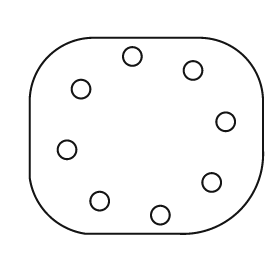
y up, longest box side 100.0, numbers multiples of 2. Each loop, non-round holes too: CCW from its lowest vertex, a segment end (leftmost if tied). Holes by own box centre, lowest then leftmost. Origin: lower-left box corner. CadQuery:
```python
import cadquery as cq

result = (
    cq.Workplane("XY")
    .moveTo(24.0, 0.0)
    .lineTo(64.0, 0.0)
    .threePointArc((90.0, 10.0), (100.0, 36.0))
    .lineTo(100.0, 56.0)
    .threePointArc((92.0, 76.0), (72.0, 84.0))
    .lineTo(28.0, 84.0)
    .threePointArc((8.0, 76.0), (0.0, 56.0))
    .lineTo(0.0, 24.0)
    .threePointArc((8.0, 8.0), (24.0, 0.0))
    .close()
    .moveTo(56.0, 8.0)
    .circle(4.0)
    .moveTo(30.0, 14.0)
    .circle(4.0)
    .moveTo(78.0, 22.0)
    .circle(4.0)
    .moveTo(16.0, 36.0)
    .circle(4.0)
    .moveTo(84.0, 48.0)
    .circle(4.0)
    .moveTo(22.0, 62.0)
    .circle(4.0)
    .moveTo(70.0, 70.0)
    .circle(4.0)
    .moveTo(44.0, 76.0)
    .circle(4.0)
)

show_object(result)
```